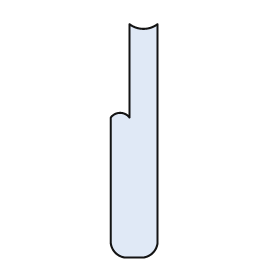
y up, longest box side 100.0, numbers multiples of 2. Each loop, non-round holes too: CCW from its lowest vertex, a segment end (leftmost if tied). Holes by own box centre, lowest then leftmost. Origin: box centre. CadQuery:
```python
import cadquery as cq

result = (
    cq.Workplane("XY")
    .moveTo(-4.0, -50.0)
    .lineTo(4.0, -50.0)
    .threePointArc((8.0, -48.0), (10.0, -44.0))
    .lineTo(10.0, 50.0)
    .threePointArc((4.0, 48.0), (-2.0, 50.0))
    .lineTo(-2.0, 10.0)
    .threePointArc((-6.0, 12.0), (-10.0, 10.0))
    .lineTo(-10.0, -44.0)
    .threePointArc((-8.0, -48.0), (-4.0, -50.0))
    .close()
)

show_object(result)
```